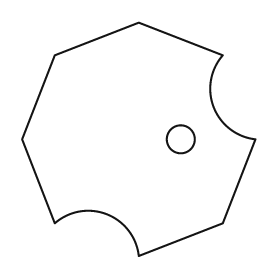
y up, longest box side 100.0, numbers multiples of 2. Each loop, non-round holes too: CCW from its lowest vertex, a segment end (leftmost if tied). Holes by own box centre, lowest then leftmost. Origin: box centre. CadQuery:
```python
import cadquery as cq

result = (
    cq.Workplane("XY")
    .moveTo(0.0, -50.0)
    .lineTo(36.0, -36.0)
    .lineTo(50.0, 0.0)
    .threePointArc((32.0, 14.0), (36.0, 36.0))
    .lineTo(0.0, 50.0)
    .lineTo(-36.0, 36.0)
    .lineTo(-50.0, 0.0)
    .lineTo(-36.0, -36.0)
    .threePointArc((-14.0, -32.0), (0.0, -50.0))
    .close()
    .moveTo(18.0, 0.0)
    .circle(6.0)
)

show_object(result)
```